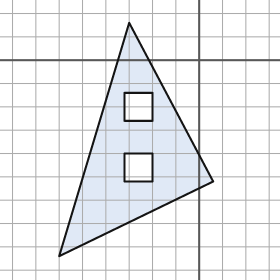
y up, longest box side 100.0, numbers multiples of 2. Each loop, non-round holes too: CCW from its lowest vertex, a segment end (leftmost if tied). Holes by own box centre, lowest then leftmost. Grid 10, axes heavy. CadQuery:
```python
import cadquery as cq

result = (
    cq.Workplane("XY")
    .moveTo(-60.0, -84.0)
    .lineTo(6.0, -52.0)
    .lineTo(-30.0, 16.0)
    .close()
    .moveTo(-32.0, -52.0)
    .lineTo(-20.0, -52.0)
    .lineTo(-20.0, -40.0)
    .lineTo(-32.0, -40.0)
    .close()
    .moveTo(-32.0, -26.0)
    .lineTo(-20.0, -26.0)
    .lineTo(-20.0, -14.0)
    .lineTo(-32.0, -14.0)
    .close()
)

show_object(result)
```